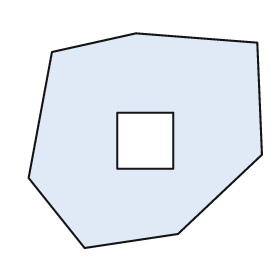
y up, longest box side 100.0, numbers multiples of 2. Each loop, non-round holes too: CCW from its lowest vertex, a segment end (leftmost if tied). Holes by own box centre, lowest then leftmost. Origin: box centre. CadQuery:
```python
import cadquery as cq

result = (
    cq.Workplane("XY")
    .moveTo(-26.0, -46.0)
    .lineTo(14.0, -40.0)
    .lineTo(50.0, -6.0)
    .lineTo(48.0, 42.0)
    .lineTo(-4.0, 46.0)
    .lineTo(-40.0, 38.0)
    .lineTo(-50.0, -16.0)
    .close()
    .moveTo(-12.0, -12.0)
    .lineTo(12.0, -12.0)
    .lineTo(12.0, 12.0)
    .lineTo(-12.0, 12.0)
    .close()
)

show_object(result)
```